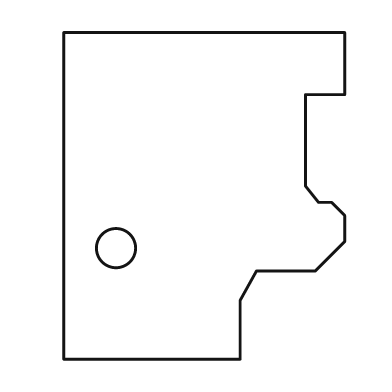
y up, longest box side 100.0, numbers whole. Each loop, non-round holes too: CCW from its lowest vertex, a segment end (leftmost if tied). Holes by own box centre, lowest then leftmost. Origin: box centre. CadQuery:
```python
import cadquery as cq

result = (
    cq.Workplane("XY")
    .moveTo(-43.0, -50.0)
    .lineTo(11.0, -50.0)
    .lineTo(11.0, -32.0)
    .lineTo(16.0, -23.0)
    .lineTo(34.0, -23.0)
    .lineTo(43.0, -14.0)
    .lineTo(43.0, -6.0)
    .lineTo(39.0, -2.0)
    .lineTo(35.0, -2.0)
    .lineTo(31.0, 3.0)
    .lineTo(31.0, 31.0)
    .lineTo(43.0, 31.0)
    .lineTo(43.0, 50.0)
    .lineTo(-43.0, 50.0)
    .close()
    .moveTo(-27.0, -16.0)
    .circle(6.0)
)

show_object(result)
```